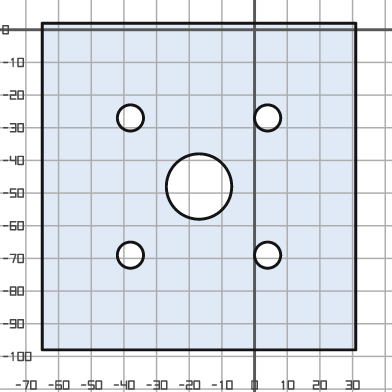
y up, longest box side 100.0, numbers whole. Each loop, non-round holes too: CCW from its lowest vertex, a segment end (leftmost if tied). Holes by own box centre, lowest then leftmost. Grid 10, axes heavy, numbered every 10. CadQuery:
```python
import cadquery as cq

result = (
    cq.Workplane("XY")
    .moveTo(-65.0, -98.0)
    .lineTo(31.0, -98.0)
    .lineTo(31.0, 2.0)
    .lineTo(-65.0, 2.0)
    .close()
    .moveTo(-38.0, -69.0)
    .circle(4.0)
    .moveTo(4.0, -69.0)
    .circle(4.0)
    .moveTo(-17.0, -48.0)
    .circle(10.0)
    .moveTo(-38.0, -27.0)
    .circle(4.0)
    .moveTo(4.0, -27.0)
    .circle(4.0)
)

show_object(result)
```